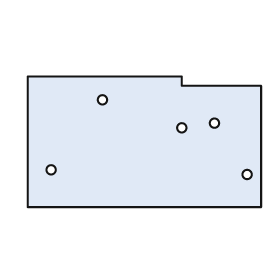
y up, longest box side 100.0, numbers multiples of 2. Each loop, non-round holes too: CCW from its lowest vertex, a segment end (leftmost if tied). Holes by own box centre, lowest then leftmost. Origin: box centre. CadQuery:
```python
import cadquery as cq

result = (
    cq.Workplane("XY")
    .moveTo(-50.0, -28.0)
    .lineTo(50.0, -28.0)
    .lineTo(50.0, 24.0)
    .lineTo(16.0, 24.0)
    .lineTo(16.0, 28.0)
    .lineTo(-50.0, 28.0)
    .close()
    .moveTo(44.0, -14.0)
    .circle(2.0)
    .moveTo(-40.0, -12.0)
    .circle(2.0)
    .moveTo(16.0, 6.0)
    .circle(2.0)
    .moveTo(30.0, 8.0)
    .circle(2.0)
    .moveTo(-18.0, 18.0)
    .circle(2.0)
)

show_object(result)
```